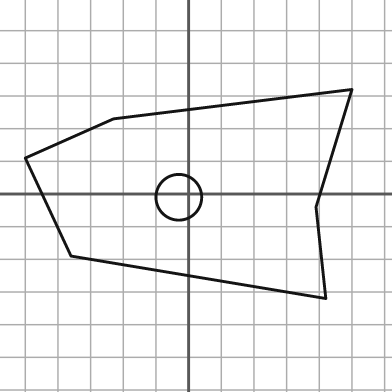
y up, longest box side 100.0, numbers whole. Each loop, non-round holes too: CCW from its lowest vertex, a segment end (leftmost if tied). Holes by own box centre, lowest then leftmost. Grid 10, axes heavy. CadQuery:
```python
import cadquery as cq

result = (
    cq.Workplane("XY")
    .moveTo(42.0, -32.0)
    .lineTo(39.0, -4.0)
    .lineTo(50.0, 32.0)
    .lineTo(-23.0, 23.0)
    .lineTo(-50.0, 11.0)
    .lineTo(-36.0, -19.0)
    .close()
    .moveTo(-3.0, -1.0)
    .circle(7.0)
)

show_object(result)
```